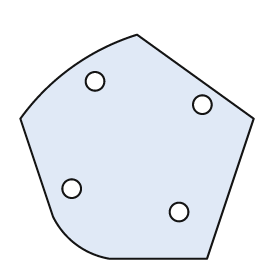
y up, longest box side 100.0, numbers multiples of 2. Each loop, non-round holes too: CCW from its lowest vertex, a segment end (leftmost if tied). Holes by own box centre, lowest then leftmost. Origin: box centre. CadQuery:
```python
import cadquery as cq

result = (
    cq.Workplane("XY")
    .moveTo(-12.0, -48.0)
    .lineTo(30.0, -48.0)
    .lineTo(50.0, 12.0)
    .lineTo(0.0, 48.0)
    .threePointArc((-28.0, 34.0), (-50.0, 12.0))
    .lineTo(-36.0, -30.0)
    .threePointArc((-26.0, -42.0), (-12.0, -48.0))
    .close()
    .moveTo(18.0, -28.0)
    .circle(4.0)
    .moveTo(-28.0, -18.0)
    .circle(4.0)
    .moveTo(28.0, 18.0)
    .circle(4.0)
    .moveTo(-18.0, 28.0)
    .circle(4.0)
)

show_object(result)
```